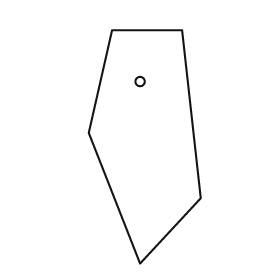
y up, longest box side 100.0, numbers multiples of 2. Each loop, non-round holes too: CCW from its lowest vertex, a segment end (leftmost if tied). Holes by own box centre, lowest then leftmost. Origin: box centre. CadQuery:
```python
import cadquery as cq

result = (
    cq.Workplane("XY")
    .moveTo(-2.0, -50.0)
    .lineTo(24.0, -22.0)
    .lineTo(16.0, 50.0)
    .lineTo(-14.0, 50.0)
    .lineTo(-24.0, 6.0)
    .close()
    .moveTo(-2.0, 28.0)
    .circle(2.0)
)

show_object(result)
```